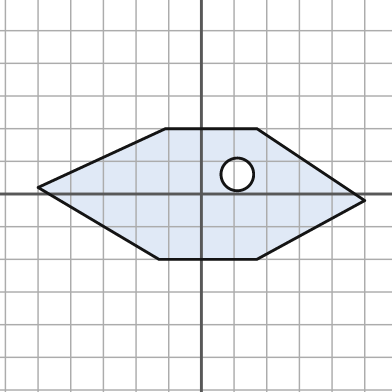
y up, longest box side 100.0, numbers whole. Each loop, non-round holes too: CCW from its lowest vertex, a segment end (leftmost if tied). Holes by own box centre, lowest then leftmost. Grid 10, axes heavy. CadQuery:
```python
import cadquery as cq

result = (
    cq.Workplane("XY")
    .moveTo(-13.0, -20.0)
    .lineTo(17.0, -20.0)
    .lineTo(50.0, -2.0)
    .lineTo(17.0, 20.0)
    .lineTo(-11.0, 20.0)
    .lineTo(-50.0, 2.0)
    .close()
    .moveTo(11.0, 6.0)
    .circle(5.0)
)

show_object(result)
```